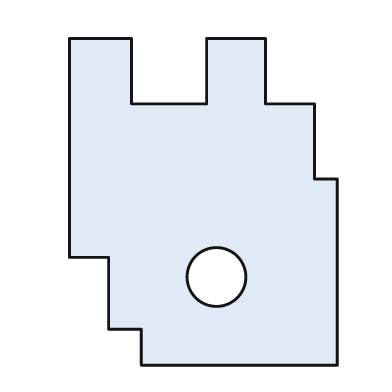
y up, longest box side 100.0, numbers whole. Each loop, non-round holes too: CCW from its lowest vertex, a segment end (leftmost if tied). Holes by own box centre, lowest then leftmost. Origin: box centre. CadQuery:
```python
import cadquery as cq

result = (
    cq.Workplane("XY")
    .moveTo(-19.0, -50.0)
    .lineTo(41.0, -50.0)
    .lineTo(41.0, 7.0)
    .lineTo(34.0, 7.0)
    .lineTo(34.0, 30.0)
    .lineTo(19.0, 30.0)
    .lineTo(19.0, 50.0)
    .lineTo(1.0, 50.0)
    .lineTo(1.0, 30.0)
    .lineTo(-22.0, 30.0)
    .lineTo(-22.0, 50.0)
    .lineTo(-41.0, 50.0)
    .lineTo(-41.0, -17.0)
    .lineTo(-29.0, -17.0)
    .lineTo(-29.0, -39.0)
    .lineTo(-19.0, -39.0)
    .close()
    .moveTo(4.0, -23.0)
    .circle(9.0)
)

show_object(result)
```